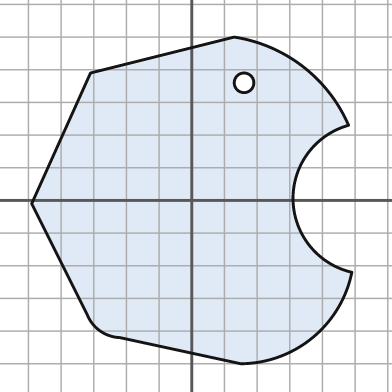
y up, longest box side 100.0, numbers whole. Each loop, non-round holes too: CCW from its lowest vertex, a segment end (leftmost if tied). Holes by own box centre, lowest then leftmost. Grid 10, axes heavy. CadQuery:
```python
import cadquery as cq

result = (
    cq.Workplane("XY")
    .moveTo(15.0, -50.0)
    .threePointArc((37.0, -42.0), (49.0, -22.0))
    .threePointArc((31.0, 0.0), (48.0, 23.0))
    .threePointArc((34.0, 41.0), (13.0, 50.0))
    .lineTo(-31.0, 39.0)
    .lineTo(-49.0, -1.0)
    .lineTo(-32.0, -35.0)
    .threePointArc((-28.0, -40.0), (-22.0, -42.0))
    .close()
    .moveTo(16.0, 36.0)
    .circle(3.0)
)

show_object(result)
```